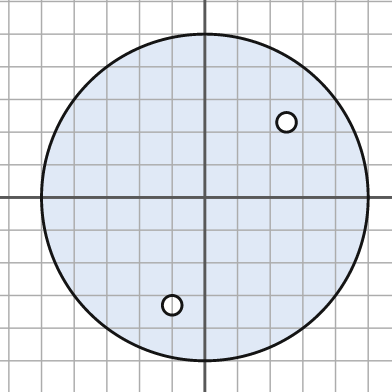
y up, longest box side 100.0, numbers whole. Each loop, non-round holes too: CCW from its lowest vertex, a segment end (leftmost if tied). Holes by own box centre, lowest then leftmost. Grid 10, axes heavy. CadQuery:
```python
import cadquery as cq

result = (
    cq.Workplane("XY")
    .moveTo(0.0, 0.0)
    .circle(50.0)
    .moveTo(-10.0, -33.0)
    .circle(3.0)
    .moveTo(25.0, 23.0)
    .circle(3.0)
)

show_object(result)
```